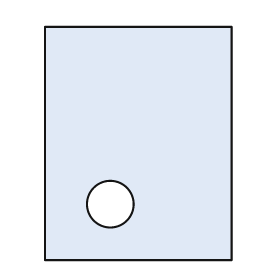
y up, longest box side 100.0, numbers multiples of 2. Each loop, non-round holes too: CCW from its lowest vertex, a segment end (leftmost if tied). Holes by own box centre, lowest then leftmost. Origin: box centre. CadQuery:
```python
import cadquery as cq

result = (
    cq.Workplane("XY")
    .moveTo(-40.0, -50.0)
    .lineTo(40.0, -50.0)
    .lineTo(40.0, 50.0)
    .lineTo(-40.0, 50.0)
    .close()
    .moveTo(-12.0, -26.0)
    .circle(10.0)
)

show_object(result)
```